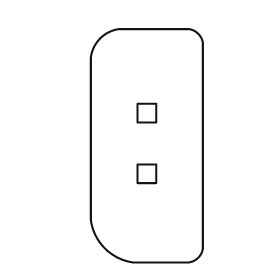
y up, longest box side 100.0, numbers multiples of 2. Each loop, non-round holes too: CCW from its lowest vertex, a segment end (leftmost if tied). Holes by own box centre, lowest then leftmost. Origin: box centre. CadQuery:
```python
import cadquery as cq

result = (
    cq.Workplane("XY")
    .moveTo(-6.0, -50.0)
    .lineTo(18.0, -50.0)
    .threePointArc((22.0, -48.0), (24.0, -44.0))
    .lineTo(24.0, 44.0)
    .threePointArc((22.0, 48.0), (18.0, 50.0))
    .lineTo(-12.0, 50.0)
    .threePointArc((-20.0, 46.0), (-24.0, 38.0))
    .lineTo(-24.0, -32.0)
    .threePointArc((-18.0, -44.0), (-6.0, -50.0))
    .close()
    .moveTo(-4.0, -16.0)
    .lineTo(4.0, -16.0)
    .lineTo(4.0, -8.0)
    .lineTo(-4.0, -8.0)
    .close()
    .moveTo(-4.0, 10.0)
    .lineTo(4.0, 10.0)
    .lineTo(4.0, 18.0)
    .lineTo(-4.0, 18.0)
    .close()
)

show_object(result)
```